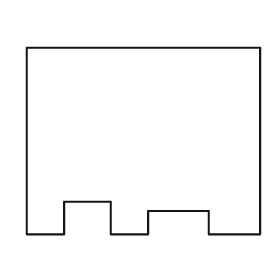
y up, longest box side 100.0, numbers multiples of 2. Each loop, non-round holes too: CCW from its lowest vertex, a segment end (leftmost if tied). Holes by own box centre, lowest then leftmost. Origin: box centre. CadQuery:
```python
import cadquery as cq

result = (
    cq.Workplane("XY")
    .moveTo(-50.0, -40.0)
    .lineTo(-34.0, -40.0)
    .lineTo(-34.0, -26.0)
    .lineTo(-14.0, -26.0)
    .lineTo(-14.0, -40.0)
    .lineTo(2.0, -40.0)
    .lineTo(2.0, -30.0)
    .lineTo(28.0, -30.0)
    .lineTo(28.0, -40.0)
    .lineTo(50.0, -40.0)
    .lineTo(50.0, 40.0)
    .lineTo(-50.0, 40.0)
    .close()
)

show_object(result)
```